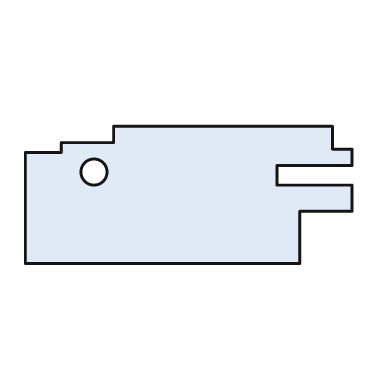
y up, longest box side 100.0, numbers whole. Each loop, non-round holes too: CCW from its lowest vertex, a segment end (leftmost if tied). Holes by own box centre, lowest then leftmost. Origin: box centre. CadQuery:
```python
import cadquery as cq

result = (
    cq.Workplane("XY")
    .moveTo(-50.0, -21.0)
    .lineTo(34.0, -21.0)
    .lineTo(34.0, -5.0)
    .lineTo(50.0, -5.0)
    .lineTo(50.0, 3.0)
    .lineTo(27.0, 3.0)
    .lineTo(27.0, 9.0)
    .lineTo(50.0, 9.0)
    .lineTo(50.0, 14.0)
    .lineTo(44.0, 14.0)
    .lineTo(44.0, 21.0)
    .lineTo(-23.0, 21.0)
    .lineTo(-23.0, 16.0)
    .lineTo(-39.0, 16.0)
    .lineTo(-39.0, 13.0)
    .lineTo(-50.0, 13.0)
    .close()
    .moveTo(-29.0, 7.0)
    .circle(4.0)
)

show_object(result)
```